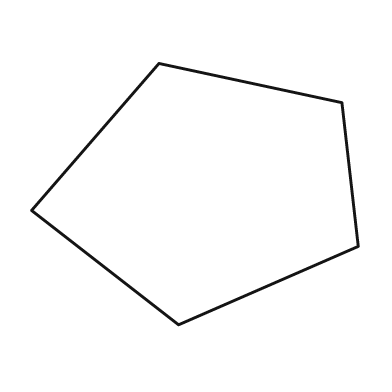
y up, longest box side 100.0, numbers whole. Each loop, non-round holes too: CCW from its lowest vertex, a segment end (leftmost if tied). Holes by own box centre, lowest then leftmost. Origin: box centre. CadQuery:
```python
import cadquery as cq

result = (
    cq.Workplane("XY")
    .moveTo(-5.0, -40.0)
    .lineTo(50.0, -16.0)
    .lineTo(45.0, 28.0)
    .lineTo(-11.0, 40.0)
    .lineTo(-50.0, -5.0)
    .close()
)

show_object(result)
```